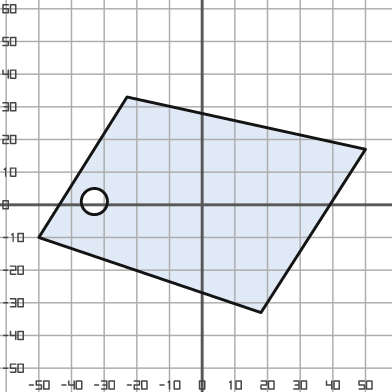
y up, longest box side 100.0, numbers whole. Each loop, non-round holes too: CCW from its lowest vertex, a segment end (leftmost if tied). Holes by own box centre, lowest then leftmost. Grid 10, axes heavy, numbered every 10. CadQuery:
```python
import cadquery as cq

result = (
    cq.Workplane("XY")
    .moveTo(18.0, -33.0)
    .lineTo(50.0, 17.0)
    .lineTo(-23.0, 33.0)
    .lineTo(-50.0, -10.0)
    .close()
    .moveTo(-33.0, 1.0)
    .circle(4.0)
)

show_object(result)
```